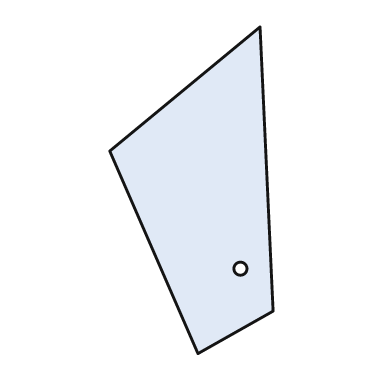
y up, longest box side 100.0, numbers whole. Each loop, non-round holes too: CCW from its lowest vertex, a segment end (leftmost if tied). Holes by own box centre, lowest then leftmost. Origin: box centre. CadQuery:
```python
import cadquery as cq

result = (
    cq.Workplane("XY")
    .moveTo(2.0, -50.0)
    .lineTo(25.0, -37.0)
    .lineTo(21.0, 50.0)
    .lineTo(-25.0, 12.0)
    .close()
    .moveTo(15.0, -24.0)
    .circle(2.0)
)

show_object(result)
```